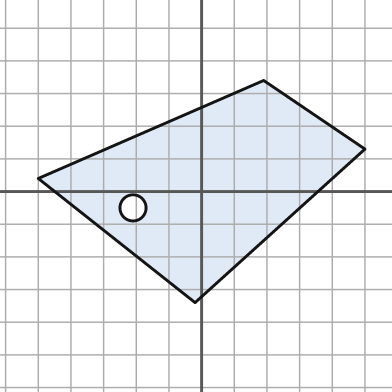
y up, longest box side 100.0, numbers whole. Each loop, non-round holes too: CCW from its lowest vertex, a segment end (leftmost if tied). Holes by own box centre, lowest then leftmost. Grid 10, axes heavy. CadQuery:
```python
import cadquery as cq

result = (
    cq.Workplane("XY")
    .moveTo(-2.0, -34.0)
    .lineTo(50.0, 13.0)
    .lineTo(19.0, 34.0)
    .lineTo(-50.0, 4.0)
    .close()
    .moveTo(-21.0, -5.0)
    .circle(4.0)
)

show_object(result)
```